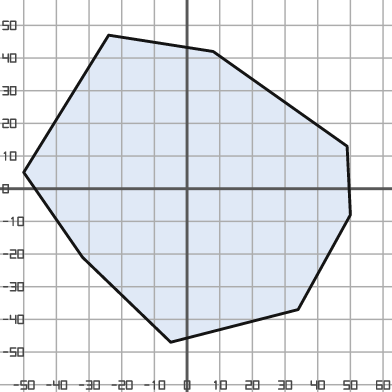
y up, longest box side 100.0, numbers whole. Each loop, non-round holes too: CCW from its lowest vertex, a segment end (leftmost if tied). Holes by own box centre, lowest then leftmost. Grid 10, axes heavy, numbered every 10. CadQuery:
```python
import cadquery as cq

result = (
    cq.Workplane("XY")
    .moveTo(-5.0, -47.0)
    .lineTo(34.0, -37.0)
    .lineTo(50.0, -8.0)
    .lineTo(49.0, 13.0)
    .lineTo(8.0, 42.0)
    .lineTo(-24.0, 47.0)
    .lineTo(-50.0, 5.0)
    .lineTo(-32.0, -21.0)
    .close()
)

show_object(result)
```